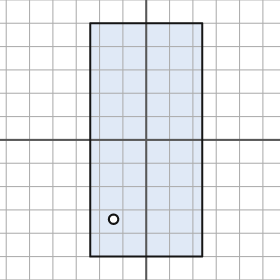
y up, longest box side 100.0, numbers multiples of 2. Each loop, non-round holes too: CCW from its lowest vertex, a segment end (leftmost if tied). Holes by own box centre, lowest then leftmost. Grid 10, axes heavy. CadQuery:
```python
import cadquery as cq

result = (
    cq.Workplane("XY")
    .moveTo(-24.0, -50.0)
    .lineTo(24.0, -50.0)
    .lineTo(24.0, 50.0)
    .lineTo(-24.0, 50.0)
    .close()
    .moveTo(-14.0, -34.0)
    .circle(2.0)
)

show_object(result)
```